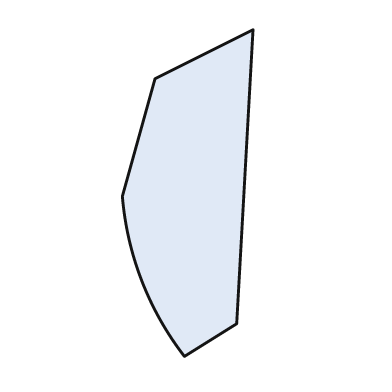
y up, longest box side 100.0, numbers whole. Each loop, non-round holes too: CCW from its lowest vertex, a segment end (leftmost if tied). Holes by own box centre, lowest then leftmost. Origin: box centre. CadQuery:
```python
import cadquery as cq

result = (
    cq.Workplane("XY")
    .moveTo(-1.0, -50.0)
    .lineTo(15.0, -40.0)
    .lineTo(20.0, 50.0)
    .lineTo(-10.0, 35.0)
    .lineTo(-20.0, -1.0)
    .threePointArc((-14.0, -27.0), (-1.0, -50.0))
    .close()
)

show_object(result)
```